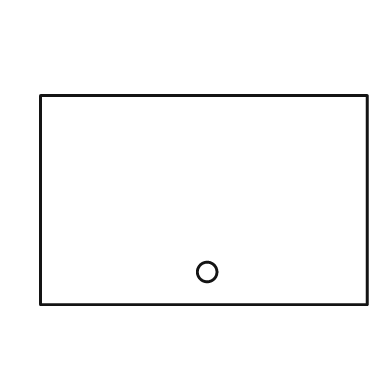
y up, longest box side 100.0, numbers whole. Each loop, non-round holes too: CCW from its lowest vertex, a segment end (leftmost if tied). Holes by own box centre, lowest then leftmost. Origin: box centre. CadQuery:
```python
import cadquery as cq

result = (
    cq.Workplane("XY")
    .moveTo(-50.0, -32.0)
    .lineTo(50.0, -32.0)
    .lineTo(50.0, 32.0)
    .lineTo(-50.0, 32.0)
    .close()
    .moveTo(1.0, -22.0)
    .circle(3.0)
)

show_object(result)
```